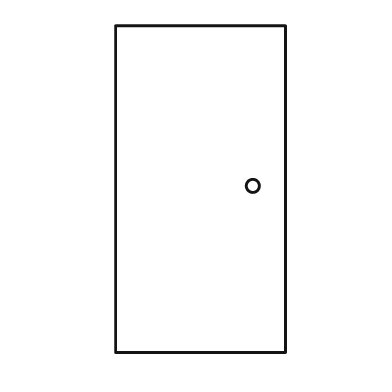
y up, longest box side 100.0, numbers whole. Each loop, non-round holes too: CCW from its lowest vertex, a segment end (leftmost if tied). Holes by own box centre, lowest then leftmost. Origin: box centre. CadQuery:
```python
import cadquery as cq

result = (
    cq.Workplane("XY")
    .moveTo(-26.0, -50.0)
    .lineTo(26.0, -50.0)
    .lineTo(26.0, 50.0)
    .lineTo(-26.0, 50.0)
    .close()
    .moveTo(16.0, 1.0)
    .circle(2.0)
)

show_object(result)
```